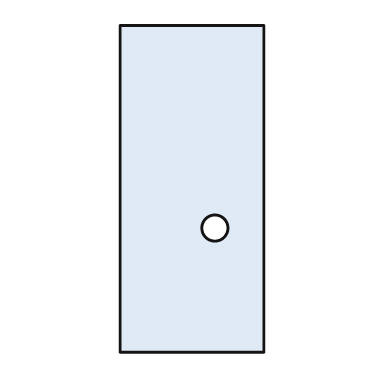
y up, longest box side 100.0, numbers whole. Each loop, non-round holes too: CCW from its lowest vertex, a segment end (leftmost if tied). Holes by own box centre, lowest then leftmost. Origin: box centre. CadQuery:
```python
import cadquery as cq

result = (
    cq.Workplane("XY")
    .moveTo(-22.0, -50.0)
    .lineTo(22.0, -50.0)
    .lineTo(22.0, 50.0)
    .lineTo(-22.0, 50.0)
    .close()
    .moveTo(7.0, -12.0)
    .circle(4.0)
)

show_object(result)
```